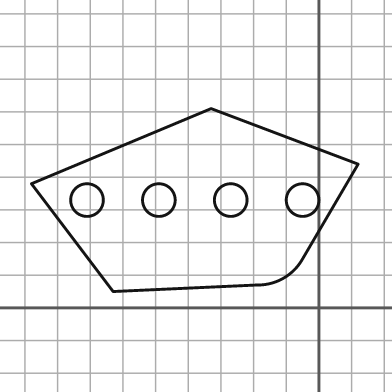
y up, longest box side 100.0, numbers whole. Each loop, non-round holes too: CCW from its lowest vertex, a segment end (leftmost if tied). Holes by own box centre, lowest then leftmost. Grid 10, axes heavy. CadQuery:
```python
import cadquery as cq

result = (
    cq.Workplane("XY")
    .moveTo(-63.0, 5.0)
    .lineTo(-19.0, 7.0)
    .threePointArc((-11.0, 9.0), (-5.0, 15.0))
    .lineTo(12.0, 44.0)
    .lineTo(-33.0, 61.0)
    .lineTo(-88.0, 38.0)
    .close()
    .moveTo(-71.0, 33.0)
    .circle(5.0)
    .moveTo(-49.0, 33.0)
    .circle(5.0)
    .moveTo(-27.0, 33.0)
    .circle(5.0)
    .moveTo(-5.0, 33.0)
    .circle(5.0)
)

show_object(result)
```